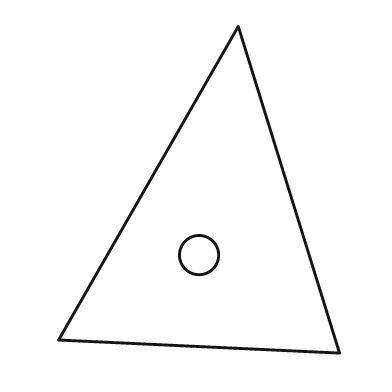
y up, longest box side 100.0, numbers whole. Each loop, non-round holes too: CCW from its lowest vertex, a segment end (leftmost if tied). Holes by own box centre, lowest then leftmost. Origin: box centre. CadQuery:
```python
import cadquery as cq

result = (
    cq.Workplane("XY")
    .moveTo(43.0, -50.0)
    .lineTo(12.0, 50.0)
    .lineTo(-43.0, -46.0)
    .close()
    .moveTo(0.0, -20.0)
    .circle(6.0)
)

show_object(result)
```